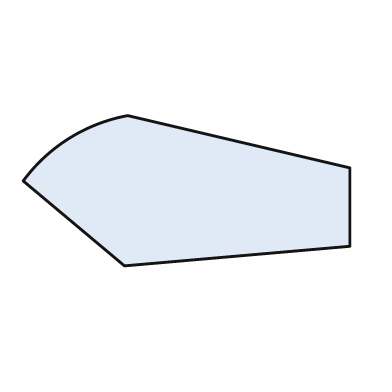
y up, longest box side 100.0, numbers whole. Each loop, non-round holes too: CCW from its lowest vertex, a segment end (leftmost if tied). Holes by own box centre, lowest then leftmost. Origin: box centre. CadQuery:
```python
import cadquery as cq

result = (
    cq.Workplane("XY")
    .moveTo(-19.0, -23.0)
    .lineTo(50.0, -17.0)
    .lineTo(50.0, 7.0)
    .lineTo(-18.0, 23.0)
    .threePointArc((-36.0, 16.0), (-50.0, 3.0))
    .close()
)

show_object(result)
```